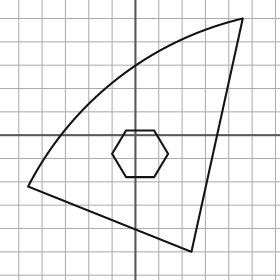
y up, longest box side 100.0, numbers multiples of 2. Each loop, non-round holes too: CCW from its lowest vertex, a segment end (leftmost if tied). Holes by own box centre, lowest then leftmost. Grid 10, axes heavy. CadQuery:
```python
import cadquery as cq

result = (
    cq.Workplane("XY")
    .moveTo(24.0, -50.0)
    .lineTo(46.0, 50.0)
    .threePointArc((-8.0, 24.0), (-46.0, -22.0))
    .close()
    .moveTo(-4.0, -18.0)
    .lineTo(8.0, -18.0)
    .lineTo(14.0, -8.0)
    .lineTo(8.0, 2.0)
    .lineTo(-4.0, 2.0)
    .lineTo(-10.0, -8.0)
    .close()
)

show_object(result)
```